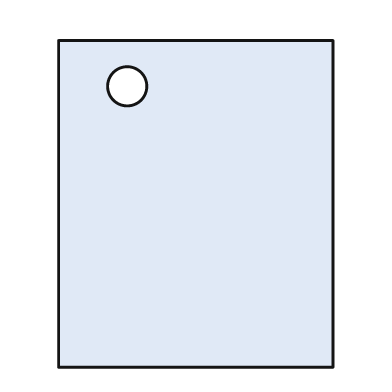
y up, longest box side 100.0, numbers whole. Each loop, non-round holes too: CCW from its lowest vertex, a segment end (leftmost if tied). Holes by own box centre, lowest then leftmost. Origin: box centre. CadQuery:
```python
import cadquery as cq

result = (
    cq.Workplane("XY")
    .moveTo(-42.0, -50.0)
    .lineTo(42.0, -50.0)
    .lineTo(42.0, 50.0)
    .lineTo(-42.0, 50.0)
    .close()
    .moveTo(-21.0, 36.0)
    .circle(6.0)
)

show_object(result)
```